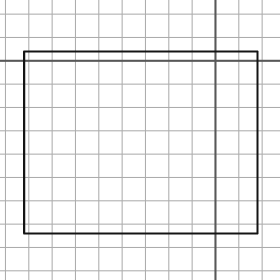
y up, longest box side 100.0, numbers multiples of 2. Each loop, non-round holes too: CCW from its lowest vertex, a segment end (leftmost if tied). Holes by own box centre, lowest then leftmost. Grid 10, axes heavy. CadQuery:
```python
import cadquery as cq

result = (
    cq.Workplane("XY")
    .moveTo(-82.0, -74.0)
    .lineTo(18.0, -74.0)
    .lineTo(18.0, 4.0)
    .lineTo(-82.0, 4.0)
    .close()
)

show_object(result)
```